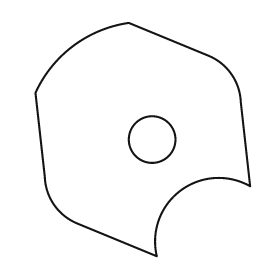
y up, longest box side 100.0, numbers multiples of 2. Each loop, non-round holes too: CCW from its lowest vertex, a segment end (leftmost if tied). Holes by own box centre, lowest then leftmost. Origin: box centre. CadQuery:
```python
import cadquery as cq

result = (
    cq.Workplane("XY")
    .moveTo(6.0, -50.0)
    .threePointArc((16.0, -22.0), (46.0, -20.0))
    .lineTo(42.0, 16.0)
    .threePointArc((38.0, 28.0), (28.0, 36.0))
    .lineTo(-6.0, 50.0)
    .threePointArc((-30.0, 40.0), (-46.0, 20.0))
    .lineTo(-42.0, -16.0)
    .threePointArc((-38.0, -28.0), (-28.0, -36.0))
    .close()
    .moveTo(4.0, 0.0)
    .circle(10.0)
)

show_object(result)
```